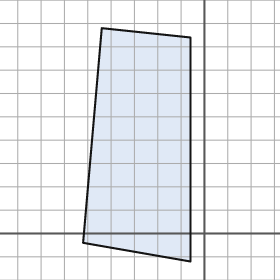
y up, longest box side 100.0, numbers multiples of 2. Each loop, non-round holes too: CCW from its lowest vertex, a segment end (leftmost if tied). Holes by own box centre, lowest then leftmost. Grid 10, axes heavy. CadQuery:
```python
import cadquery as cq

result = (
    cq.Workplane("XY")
    .moveTo(-6.0, -12.0)
    .lineTo(-6.0, 84.0)
    .lineTo(-44.0, 88.0)
    .lineTo(-52.0, -4.0)
    .close()
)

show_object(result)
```